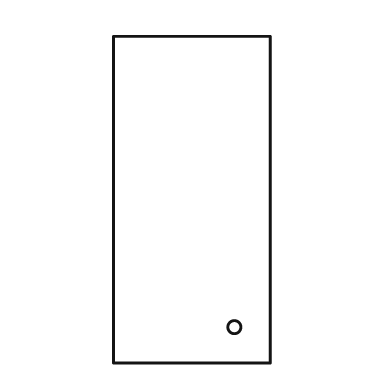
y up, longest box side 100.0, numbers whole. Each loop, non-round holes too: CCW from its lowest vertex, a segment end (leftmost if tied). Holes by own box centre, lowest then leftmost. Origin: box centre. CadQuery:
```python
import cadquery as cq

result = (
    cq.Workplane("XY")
    .moveTo(-24.0, -50.0)
    .lineTo(24.0, -50.0)
    .lineTo(24.0, 50.0)
    .lineTo(-24.0, 50.0)
    .close()
    .moveTo(13.0, -39.0)
    .circle(2.0)
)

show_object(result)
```